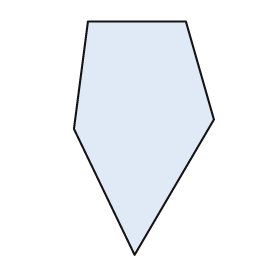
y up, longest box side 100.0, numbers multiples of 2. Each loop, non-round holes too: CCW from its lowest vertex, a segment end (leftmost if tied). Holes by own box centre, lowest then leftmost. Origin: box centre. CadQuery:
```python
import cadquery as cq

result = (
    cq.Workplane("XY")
    .moveTo(-4.0, -50.0)
    .lineTo(30.0, 8.0)
    .lineTo(18.0, 50.0)
    .lineTo(-24.0, 50.0)
    .lineTo(-30.0, 4.0)
    .close()
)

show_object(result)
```